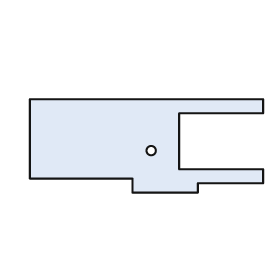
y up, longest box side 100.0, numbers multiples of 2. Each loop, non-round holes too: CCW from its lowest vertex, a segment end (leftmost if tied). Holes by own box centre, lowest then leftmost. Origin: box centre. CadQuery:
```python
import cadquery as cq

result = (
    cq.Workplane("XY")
    .moveTo(-6.0, -20.0)
    .lineTo(22.0, -20.0)
    .lineTo(22.0, -16.0)
    .lineTo(50.0, -16.0)
    .lineTo(50.0, -10.0)
    .lineTo(14.0, -10.0)
    .lineTo(14.0, 14.0)
    .lineTo(50.0, 14.0)
    .lineTo(50.0, 20.0)
    .lineTo(-50.0, 20.0)
    .lineTo(-50.0, -14.0)
    .lineTo(-6.0, -14.0)
    .close()
    .moveTo(2.0, -2.0)
    .circle(2.0)
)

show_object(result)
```